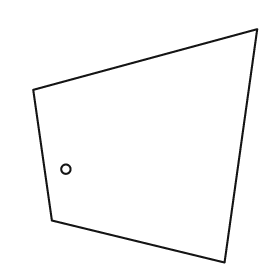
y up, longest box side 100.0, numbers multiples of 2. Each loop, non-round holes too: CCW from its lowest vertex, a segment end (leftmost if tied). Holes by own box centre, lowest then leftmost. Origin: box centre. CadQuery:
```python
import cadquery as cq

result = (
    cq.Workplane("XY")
    .moveTo(34.0, -50.0)
    .lineTo(48.0, 50.0)
    .lineTo(-48.0, 24.0)
    .lineTo(-40.0, -32.0)
    .close()
    .moveTo(-34.0, -10.0)
    .circle(2.0)
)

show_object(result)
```